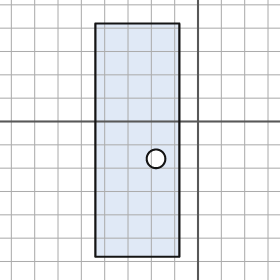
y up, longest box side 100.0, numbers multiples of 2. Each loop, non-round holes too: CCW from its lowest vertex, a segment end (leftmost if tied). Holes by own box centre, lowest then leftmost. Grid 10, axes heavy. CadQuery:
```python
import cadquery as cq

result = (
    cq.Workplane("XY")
    .moveTo(-44.0, -58.0)
    .lineTo(-8.0, -58.0)
    .lineTo(-8.0, 42.0)
    .lineTo(-44.0, 42.0)
    .close()
    .moveTo(-18.0, -16.0)
    .circle(4.0)
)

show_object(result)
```